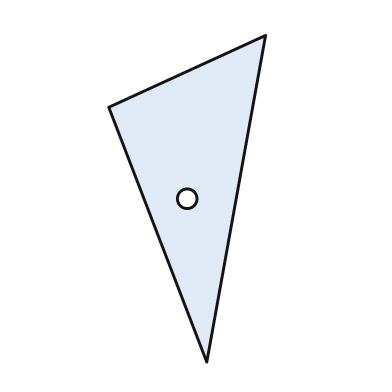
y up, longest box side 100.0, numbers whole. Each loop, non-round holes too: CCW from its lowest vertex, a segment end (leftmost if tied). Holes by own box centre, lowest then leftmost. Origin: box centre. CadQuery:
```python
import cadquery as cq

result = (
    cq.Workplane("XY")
    .moveTo(6.0, -50.0)
    .lineTo(24.0, 50.0)
    .lineTo(-24.0, 28.0)
    .close()
    .moveTo(0.0, 0.0)
    .circle(3.0)
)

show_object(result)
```